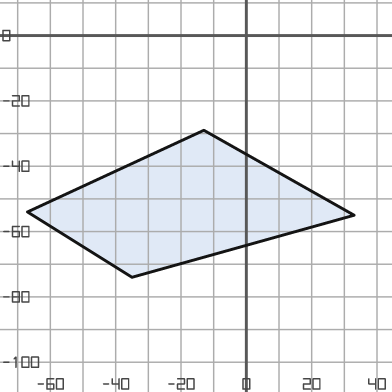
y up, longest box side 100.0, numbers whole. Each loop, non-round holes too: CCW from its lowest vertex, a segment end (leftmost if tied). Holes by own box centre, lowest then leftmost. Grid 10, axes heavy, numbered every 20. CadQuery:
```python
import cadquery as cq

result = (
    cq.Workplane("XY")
    .moveTo(-35.0, -74.0)
    .lineTo(33.0, -55.0)
    .lineTo(-13.0, -29.0)
    .lineTo(-67.0, -54.0)
    .close()
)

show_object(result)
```